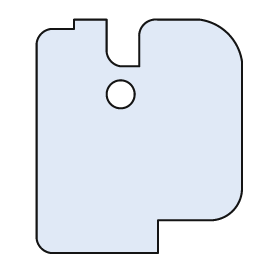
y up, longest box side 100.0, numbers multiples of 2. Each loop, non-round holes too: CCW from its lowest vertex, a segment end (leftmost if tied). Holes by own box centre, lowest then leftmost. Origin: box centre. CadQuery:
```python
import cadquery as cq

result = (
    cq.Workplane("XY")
    .moveTo(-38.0, -50.0)
    .lineTo(8.0, -50.0)
    .lineTo(8.0, -36.0)
    .lineTo(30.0, -36.0)
    .threePointArc((40.0, -32.0), (44.0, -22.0))
    .lineTo(44.0, 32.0)
    .threePointArc((38.0, 44.0), (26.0, 50.0))
    .lineTo(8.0, 50.0)
    .threePointArc((2.0, 48.0), (0.0, 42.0))
    .lineTo(0.0, 30.0)
    .lineTo(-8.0, 30.0)
    .threePointArc((-12.0, 32.0), (-14.0, 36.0))
    .lineTo(-14.0, 50.0)
    .lineTo(-28.0, 50.0)
    .lineTo(-28.0, 46.0)
    .lineTo(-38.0, 46.0)
    .threePointArc((-42.0, 44.0), (-44.0, 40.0))
    .lineTo(-44.0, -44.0)
    .threePointArc((-42.0, -48.0), (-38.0, -50.0))
    .close()
    .moveTo(-8.0, 18.0)
    .circle(6.0)
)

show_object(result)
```